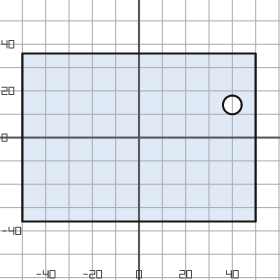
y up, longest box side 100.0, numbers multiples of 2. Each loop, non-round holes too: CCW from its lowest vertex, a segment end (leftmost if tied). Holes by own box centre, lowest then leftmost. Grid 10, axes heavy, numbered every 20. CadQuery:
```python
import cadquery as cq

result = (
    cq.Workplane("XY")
    .moveTo(-50.0, -36.0)
    .lineTo(50.0, -36.0)
    .lineTo(50.0, 36.0)
    .lineTo(-50.0, 36.0)
    .close()
    .moveTo(40.0, 14.0)
    .circle(4.0)
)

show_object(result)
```